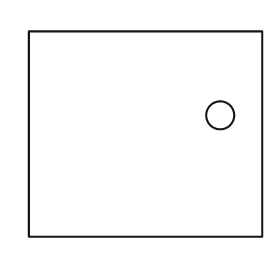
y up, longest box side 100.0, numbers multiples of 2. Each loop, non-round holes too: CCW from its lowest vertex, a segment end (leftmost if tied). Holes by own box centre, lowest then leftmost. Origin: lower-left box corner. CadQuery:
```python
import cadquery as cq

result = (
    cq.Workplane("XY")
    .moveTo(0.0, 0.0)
    .lineTo(100.0, 0.0)
    .lineTo(100.0, 88.0)
    .lineTo(0.0, 88.0)
    .close()
    .moveTo(82.0, 52.0)
    .circle(6.0)
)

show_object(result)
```